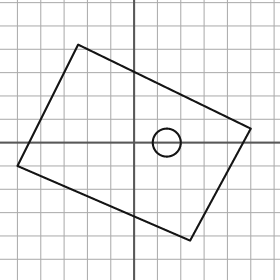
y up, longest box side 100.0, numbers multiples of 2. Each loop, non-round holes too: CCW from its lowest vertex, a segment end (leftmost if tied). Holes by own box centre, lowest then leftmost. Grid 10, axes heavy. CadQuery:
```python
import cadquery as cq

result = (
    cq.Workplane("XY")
    .moveTo(24.0, -42.0)
    .lineTo(50.0, 6.0)
    .lineTo(-24.0, 42.0)
    .lineTo(-50.0, -10.0)
    .close()
    .moveTo(14.0, 0.0)
    .circle(6.0)
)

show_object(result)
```